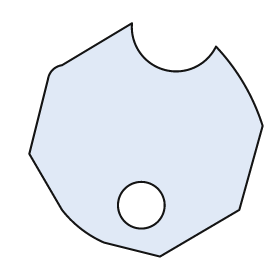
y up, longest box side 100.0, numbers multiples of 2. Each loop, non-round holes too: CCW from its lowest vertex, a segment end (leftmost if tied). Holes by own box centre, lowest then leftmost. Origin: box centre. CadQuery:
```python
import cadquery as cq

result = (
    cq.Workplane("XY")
    .moveTo(6.0, -50.0)
    .lineTo(40.0, -30.0)
    .lineTo(50.0, 6.0)
    .threePointArc((42.0, 24.0), (30.0, 40.0))
    .threePointArc((8.0, 30.0), (-6.0, 50.0))
    .lineTo(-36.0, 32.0)
    .threePointArc((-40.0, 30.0), (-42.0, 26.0))
    .lineTo(-50.0, -6.0)
    .lineTo(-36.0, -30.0)
    .threePointArc((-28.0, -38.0), (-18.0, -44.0))
    .close()
    .moveTo(-2.0, -28.0)
    .circle(10.0)
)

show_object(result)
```